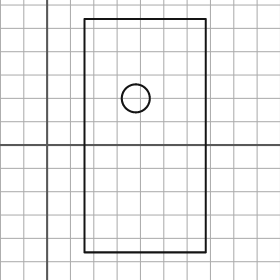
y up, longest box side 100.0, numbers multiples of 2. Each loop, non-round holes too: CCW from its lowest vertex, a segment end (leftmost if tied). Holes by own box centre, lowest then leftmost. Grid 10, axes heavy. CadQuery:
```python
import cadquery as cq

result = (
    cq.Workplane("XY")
    .moveTo(16.0, -46.0)
    .lineTo(68.0, -46.0)
    .lineTo(68.0, 54.0)
    .lineTo(16.0, 54.0)
    .close()
    .moveTo(38.0, 20.0)
    .circle(6.0)
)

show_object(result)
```